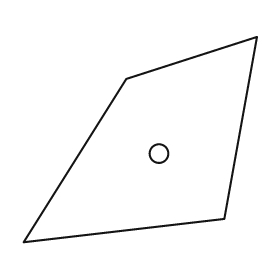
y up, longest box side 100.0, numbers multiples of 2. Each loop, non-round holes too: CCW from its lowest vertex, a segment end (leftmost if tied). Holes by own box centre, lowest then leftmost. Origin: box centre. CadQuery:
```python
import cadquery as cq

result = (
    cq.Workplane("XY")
    .moveTo(-50.0, -44.0)
    .lineTo(36.0, -34.0)
    .lineTo(50.0, 44.0)
    .lineTo(-6.0, 26.0)
    .close()
    .moveTo(8.0, -6.0)
    .circle(4.0)
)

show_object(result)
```